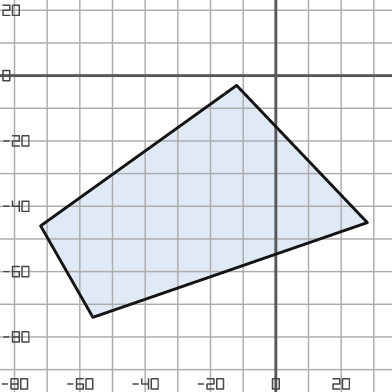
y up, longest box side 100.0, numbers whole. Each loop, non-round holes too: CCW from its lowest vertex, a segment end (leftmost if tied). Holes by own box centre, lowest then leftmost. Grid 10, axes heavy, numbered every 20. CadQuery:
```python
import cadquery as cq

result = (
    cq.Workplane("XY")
    .moveTo(-56.0, -74.0)
    .lineTo(28.0, -45.0)
    .lineTo(-12.0, -3.0)
    .lineTo(-72.0, -46.0)
    .close()
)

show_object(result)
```